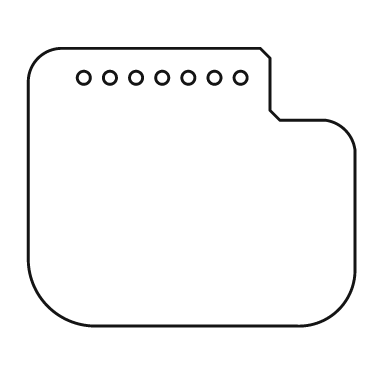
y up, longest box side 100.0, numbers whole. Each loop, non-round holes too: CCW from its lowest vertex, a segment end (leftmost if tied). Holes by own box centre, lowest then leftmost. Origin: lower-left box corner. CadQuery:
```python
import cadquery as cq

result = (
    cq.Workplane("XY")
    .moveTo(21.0, 0.0)
    .lineTo(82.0, 0.0)
    .threePointArc((95.0, 5.0), (100.0, 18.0))
    .lineTo(100.0, 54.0)
    .threePointArc((97.0, 60.0), (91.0, 63.0))
    .lineTo(77.0, 63.0)
    .lineTo(74.0, 66.0)
    .lineTo(74.0, 82.0)
    .lineTo(71.0, 85.0)
    .lineTo(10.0, 85.0)
    .threePointArc((3.0, 82.0), (0.0, 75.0))
    .lineTo(0.0, 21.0)
    .threePointArc((6.0, 6.0), (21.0, 0.0))
    .close()
    .moveTo(17.0, 76.0)
    .circle(2.0)
    .moveTo(25.0, 76.0)
    .circle(2.0)
    .moveTo(33.0, 76.0)
    .circle(2.0)
    .moveTo(41.0, 76.0)
    .circle(2.0)
    .moveTo(49.0, 76.0)
    .circle(2.0)
    .moveTo(57.0, 76.0)
    .circle(2.0)
    .moveTo(65.0, 76.0)
    .circle(2.0)
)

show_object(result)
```